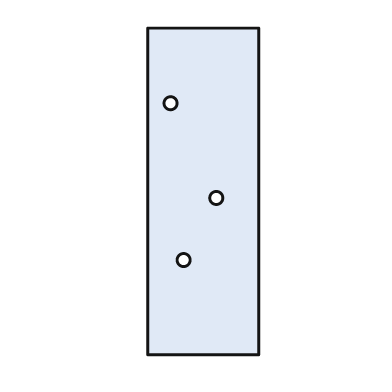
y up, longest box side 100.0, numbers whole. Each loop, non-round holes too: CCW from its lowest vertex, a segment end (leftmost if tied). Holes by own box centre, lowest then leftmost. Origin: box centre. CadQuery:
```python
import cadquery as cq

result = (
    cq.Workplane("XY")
    .moveTo(-17.0, -50.0)
    .lineTo(17.0, -50.0)
    .lineTo(17.0, 50.0)
    .lineTo(-17.0, 50.0)
    .close()
    .moveTo(-6.0, -21.0)
    .circle(2.0)
    .moveTo(4.0, -2.0)
    .circle(2.0)
    .moveTo(-10.0, 27.0)
    .circle(2.0)
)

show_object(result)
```